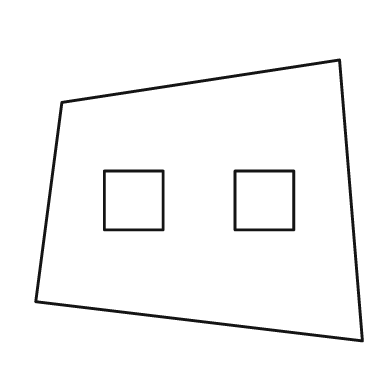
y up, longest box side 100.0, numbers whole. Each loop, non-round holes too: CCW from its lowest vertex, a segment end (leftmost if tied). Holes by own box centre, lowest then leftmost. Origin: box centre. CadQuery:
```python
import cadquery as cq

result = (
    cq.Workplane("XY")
    .moveTo(50.0, -43.0)
    .lineTo(43.0, 43.0)
    .lineTo(-42.0, 30.0)
    .lineTo(-50.0, -31.0)
    .close()
    .moveTo(-29.0, -9.0)
    .lineTo(-11.0, -9.0)
    .lineTo(-11.0, 9.0)
    .lineTo(-29.0, 9.0)
    .close()
    .moveTo(11.0, -9.0)
    .lineTo(29.0, -9.0)
    .lineTo(29.0, 9.0)
    .lineTo(11.0, 9.0)
    .close()
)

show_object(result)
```